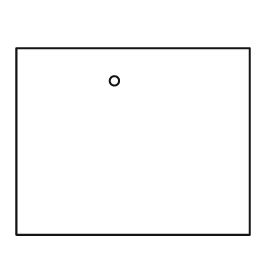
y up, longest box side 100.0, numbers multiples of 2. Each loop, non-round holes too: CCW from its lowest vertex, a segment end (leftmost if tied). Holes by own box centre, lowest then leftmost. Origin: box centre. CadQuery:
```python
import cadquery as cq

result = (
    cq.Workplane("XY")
    .moveTo(-50.0, -40.0)
    .lineTo(50.0, -40.0)
    .lineTo(50.0, 40.0)
    .lineTo(-50.0, 40.0)
    .close()
    .moveTo(-8.0, 26.0)
    .circle(2.0)
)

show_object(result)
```